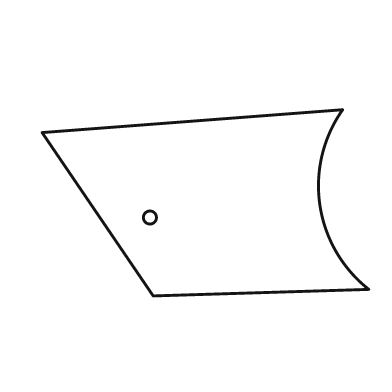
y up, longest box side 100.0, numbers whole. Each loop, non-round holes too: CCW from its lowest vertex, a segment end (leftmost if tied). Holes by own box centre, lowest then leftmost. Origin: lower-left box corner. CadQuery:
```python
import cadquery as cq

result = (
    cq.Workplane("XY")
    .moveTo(34.0, 0.0)
    .lineTo(100.0, 2.0)
    .threePointArc((85.0, 28.0), (92.0, 57.0))
    .lineTo(0.0, 50.0)
    .close()
    .moveTo(33.0, 24.0)
    .circle(2.0)
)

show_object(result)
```